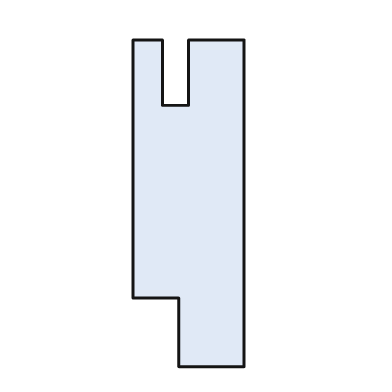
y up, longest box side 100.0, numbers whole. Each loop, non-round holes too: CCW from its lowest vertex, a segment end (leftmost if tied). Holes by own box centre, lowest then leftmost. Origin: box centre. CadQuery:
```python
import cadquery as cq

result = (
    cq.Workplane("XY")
    .moveTo(-3.0, -50.0)
    .lineTo(17.0, -50.0)
    .lineTo(17.0, 50.0)
    .lineTo(0.0, 50.0)
    .lineTo(0.0, 30.0)
    .lineTo(-8.0, 30.0)
    .lineTo(-8.0, 50.0)
    .lineTo(-17.0, 50.0)
    .lineTo(-17.0, -29.0)
    .lineTo(-3.0, -29.0)
    .close()
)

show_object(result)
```